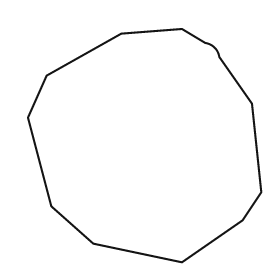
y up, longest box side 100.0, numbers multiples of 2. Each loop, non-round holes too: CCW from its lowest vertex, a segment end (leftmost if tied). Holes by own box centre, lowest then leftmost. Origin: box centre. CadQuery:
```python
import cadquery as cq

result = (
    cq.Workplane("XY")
    .moveTo(16.0, -50.0)
    .lineTo(42.0, -32.0)
    .lineTo(50.0, -20.0)
    .lineTo(46.0, 18.0)
    .lineTo(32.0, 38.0)
    .threePointArc((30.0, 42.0), (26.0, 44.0))
    .lineTo(16.0, 50.0)
    .lineTo(-10.0, 48.0)
    .lineTo(-42.0, 30.0)
    .lineTo(-50.0, 12.0)
    .lineTo(-40.0, -26.0)
    .lineTo(-22.0, -42.0)
    .close()
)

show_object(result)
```